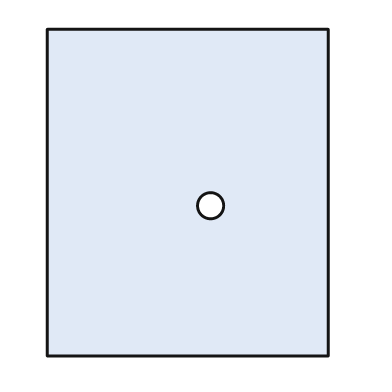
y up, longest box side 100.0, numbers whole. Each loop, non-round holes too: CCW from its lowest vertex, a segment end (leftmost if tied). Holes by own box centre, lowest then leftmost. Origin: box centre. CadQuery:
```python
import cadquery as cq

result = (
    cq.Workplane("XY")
    .moveTo(-43.0, -50.0)
    .lineTo(43.0, -50.0)
    .lineTo(43.0, 50.0)
    .lineTo(-43.0, 50.0)
    .close()
    .moveTo(7.0, -4.0)
    .circle(4.0)
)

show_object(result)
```